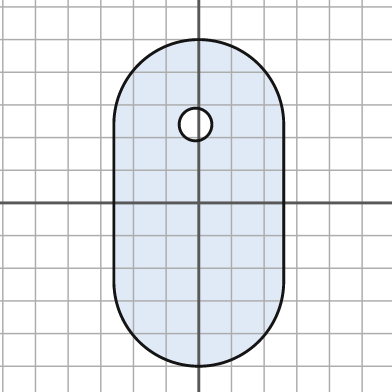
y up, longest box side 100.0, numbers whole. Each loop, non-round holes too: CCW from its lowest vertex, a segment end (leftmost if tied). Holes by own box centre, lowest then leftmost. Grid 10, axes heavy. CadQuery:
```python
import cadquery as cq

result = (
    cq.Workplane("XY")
    .moveTo(-26.0, -24.0)
    .threePointArc((0.0, -50.0), (26.0, -24.0))
    .lineTo(26.0, 24.0)
    .threePointArc((0.0, 50.0), (-26.0, 24.0))
    .close()
    .moveTo(-1.0, 24.0)
    .circle(5.0)
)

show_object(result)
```